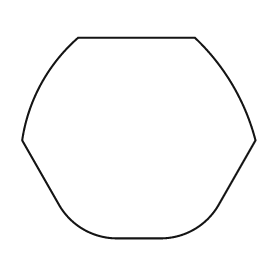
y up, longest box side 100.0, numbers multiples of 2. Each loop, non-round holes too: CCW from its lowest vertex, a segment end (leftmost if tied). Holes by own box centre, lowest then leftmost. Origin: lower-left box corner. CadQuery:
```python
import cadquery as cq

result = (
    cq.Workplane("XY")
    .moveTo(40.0, 0.0)
    .lineTo(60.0, 0.0)
    .threePointArc((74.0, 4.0), (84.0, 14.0))
    .lineTo(100.0, 42.0)
    .threePointArc((90.0, 66.0), (74.0, 86.0))
    .lineTo(24.0, 86.0)
    .threePointArc((8.0, 66.0), (0.0, 42.0))
    .lineTo(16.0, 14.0)
    .threePointArc((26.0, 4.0), (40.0, 0.0))
    .close()
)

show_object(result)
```